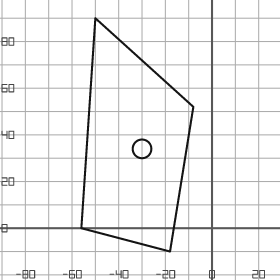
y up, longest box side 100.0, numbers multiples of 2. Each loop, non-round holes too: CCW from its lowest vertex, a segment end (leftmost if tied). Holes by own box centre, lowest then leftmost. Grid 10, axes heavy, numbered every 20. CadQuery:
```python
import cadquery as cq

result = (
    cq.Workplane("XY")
    .moveTo(-18.0, -10.0)
    .lineTo(-8.0, 52.0)
    .lineTo(-50.0, 90.0)
    .lineTo(-56.0, 0.0)
    .close()
    .moveTo(-30.0, 34.0)
    .circle(4.0)
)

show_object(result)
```